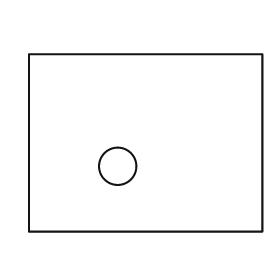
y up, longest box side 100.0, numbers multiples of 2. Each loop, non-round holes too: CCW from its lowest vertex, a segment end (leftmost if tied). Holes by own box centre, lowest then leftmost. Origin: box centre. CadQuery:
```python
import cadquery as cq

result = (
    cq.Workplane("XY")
    .moveTo(-50.0, -38.0)
    .lineTo(50.0, -38.0)
    .lineTo(50.0, 38.0)
    .lineTo(-50.0, 38.0)
    .close()
    .moveTo(-12.0, -10.0)
    .circle(8.0)
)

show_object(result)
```